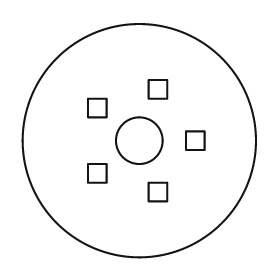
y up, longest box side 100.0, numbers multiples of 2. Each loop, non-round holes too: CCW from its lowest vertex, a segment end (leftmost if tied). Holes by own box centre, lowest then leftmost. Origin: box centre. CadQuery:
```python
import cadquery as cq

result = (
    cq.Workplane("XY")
    .moveTo(0.0, 0.0)
    .circle(50.0)
    .moveTo(4.0, -26.0)
    .lineTo(12.0, -26.0)
    .lineTo(12.0, -18.0)
    .lineTo(4.0, -18.0)
    .close()
    .moveTo(-22.0, -18.0)
    .lineTo(-14.0, -18.0)
    .lineTo(-14.0, -10.0)
    .lineTo(-22.0, -10.0)
    .close()
    .moveTo(0.0, 0.0)
    .circle(10.0)
    .moveTo(20.0, -4.0)
    .lineTo(28.0, -4.0)
    .lineTo(28.0, 4.0)
    .lineTo(20.0, 4.0)
    .close()
    .moveTo(-22.0, 10.0)
    .lineTo(-14.0, 10.0)
    .lineTo(-14.0, 18.0)
    .lineTo(-22.0, 18.0)
    .close()
    .moveTo(4.0, 18.0)
    .lineTo(12.0, 18.0)
    .lineTo(12.0, 26.0)
    .lineTo(4.0, 26.0)
    .close()
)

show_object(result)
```